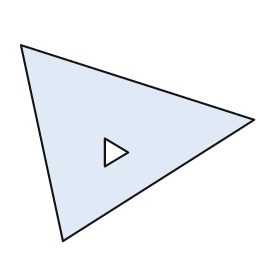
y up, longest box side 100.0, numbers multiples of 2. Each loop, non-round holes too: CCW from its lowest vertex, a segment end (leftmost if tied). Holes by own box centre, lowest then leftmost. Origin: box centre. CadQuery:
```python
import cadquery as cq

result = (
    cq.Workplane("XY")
    .moveTo(-32.0, -42.0)
    .lineTo(50.0, 10.0)
    .lineTo(-50.0, 42.0)
    .close()
    .moveTo(-14.0, -10.0)
    .lineTo(-4.0, -4.0)
    .lineTo(-14.0, 2.0)
    .close()
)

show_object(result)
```